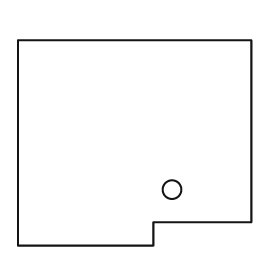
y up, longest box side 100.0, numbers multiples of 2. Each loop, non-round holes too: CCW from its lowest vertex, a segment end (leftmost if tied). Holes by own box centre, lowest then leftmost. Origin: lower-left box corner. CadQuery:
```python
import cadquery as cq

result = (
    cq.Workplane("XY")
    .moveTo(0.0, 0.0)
    .lineTo(58.0, 0.0)
    .lineTo(58.0, 10.0)
    .lineTo(100.0, 10.0)
    .lineTo(100.0, 88.0)
    .lineTo(0.0, 88.0)
    .close()
    .moveTo(66.0, 24.0)
    .circle(4.0)
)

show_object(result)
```